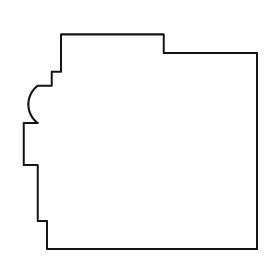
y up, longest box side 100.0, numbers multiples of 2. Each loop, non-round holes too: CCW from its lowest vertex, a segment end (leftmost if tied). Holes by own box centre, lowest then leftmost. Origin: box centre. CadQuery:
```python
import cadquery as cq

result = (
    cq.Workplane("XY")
    .moveTo(-40.0, -46.0)
    .lineTo(50.0, -46.0)
    .lineTo(50.0, 38.0)
    .lineTo(10.0, 38.0)
    .lineTo(10.0, 46.0)
    .lineTo(-34.0, 46.0)
    .lineTo(-34.0, 30.0)
    .lineTo(-38.0, 30.0)
    .lineTo(-38.0, 24.0)
    .lineTo(-44.0, 24.0)
    .threePointArc((-48.0, 16.0), (-44.0, 8.0))
    .lineTo(-50.0, 8.0)
    .lineTo(-50.0, -10.0)
    .lineTo(-44.0, -10.0)
    .lineTo(-44.0, -34.0)
    .lineTo(-40.0, -34.0)
    .close()
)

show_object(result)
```